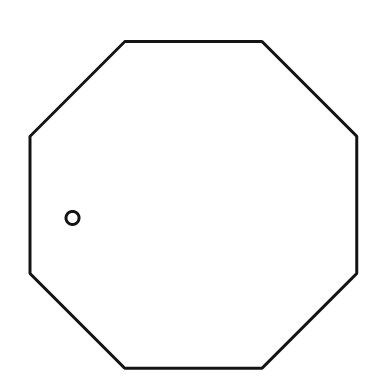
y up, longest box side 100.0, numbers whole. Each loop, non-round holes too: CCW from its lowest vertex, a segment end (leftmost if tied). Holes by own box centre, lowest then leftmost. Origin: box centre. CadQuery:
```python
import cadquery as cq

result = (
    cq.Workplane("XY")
    .moveTo(-21.0, -50.0)
    .lineTo(21.0, -50.0)
    .lineTo(50.0, -21.0)
    .lineTo(50.0, 21.0)
    .lineTo(21.0, 50.0)
    .lineTo(-21.0, 50.0)
    .lineTo(-50.0, 21.0)
    .lineTo(-50.0, -21.0)
    .close()
    .moveTo(-37.0, -4.0)
    .circle(2.0)
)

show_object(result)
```